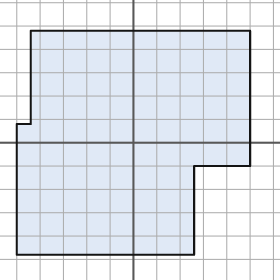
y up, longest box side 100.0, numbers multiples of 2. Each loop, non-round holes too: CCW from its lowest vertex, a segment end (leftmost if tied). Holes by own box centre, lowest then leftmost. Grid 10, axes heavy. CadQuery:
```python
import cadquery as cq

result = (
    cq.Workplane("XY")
    .moveTo(-50.0, -48.0)
    .lineTo(26.0, -48.0)
    .lineTo(26.0, -10.0)
    .lineTo(50.0, -10.0)
    .lineTo(50.0, 48.0)
    .lineTo(-44.0, 48.0)
    .lineTo(-44.0, 8.0)
    .lineTo(-50.0, 8.0)
    .close()
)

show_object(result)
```